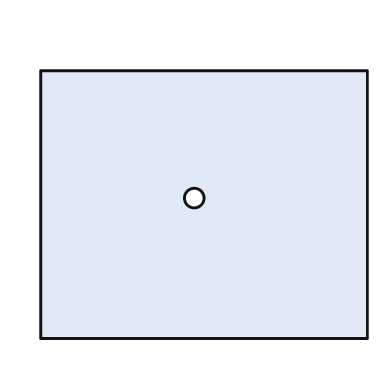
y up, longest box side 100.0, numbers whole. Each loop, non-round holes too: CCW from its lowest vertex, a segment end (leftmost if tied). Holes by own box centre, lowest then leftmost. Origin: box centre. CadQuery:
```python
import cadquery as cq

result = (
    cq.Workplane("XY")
    .moveTo(-50.0, -41.0)
    .lineTo(50.0, -41.0)
    .lineTo(50.0, 41.0)
    .lineTo(-50.0, 41.0)
    .close()
    .moveTo(-3.0, 2.0)
    .circle(3.0)
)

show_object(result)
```